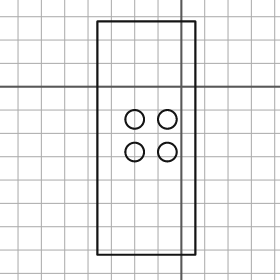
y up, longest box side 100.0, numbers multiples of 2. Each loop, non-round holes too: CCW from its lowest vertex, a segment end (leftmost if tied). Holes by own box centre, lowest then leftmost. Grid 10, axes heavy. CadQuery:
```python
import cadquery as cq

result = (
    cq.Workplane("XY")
    .moveTo(-36.0, -72.0)
    .lineTo(6.0, -72.0)
    .lineTo(6.0, 28.0)
    .lineTo(-36.0, 28.0)
    .close()
    .moveTo(-20.0, -28.0)
    .circle(4.0)
    .moveTo(-6.0, -28.0)
    .circle(4.0)
    .moveTo(-20.0, -14.0)
    .circle(4.0)
    .moveTo(-6.0, -14.0)
    .circle(4.0)
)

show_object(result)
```